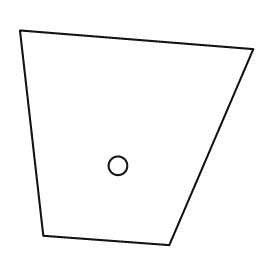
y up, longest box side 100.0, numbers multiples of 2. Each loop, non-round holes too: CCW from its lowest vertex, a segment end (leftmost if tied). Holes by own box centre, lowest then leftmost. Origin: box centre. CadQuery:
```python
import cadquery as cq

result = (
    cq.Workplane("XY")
    .moveTo(14.0, -46.0)
    .lineTo(50.0, 38.0)
    .lineTo(-50.0, 46.0)
    .lineTo(-40.0, -42.0)
    .close()
    .moveTo(-8.0, -12.0)
    .circle(4.0)
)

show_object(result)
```